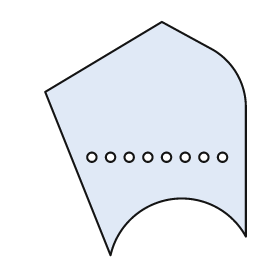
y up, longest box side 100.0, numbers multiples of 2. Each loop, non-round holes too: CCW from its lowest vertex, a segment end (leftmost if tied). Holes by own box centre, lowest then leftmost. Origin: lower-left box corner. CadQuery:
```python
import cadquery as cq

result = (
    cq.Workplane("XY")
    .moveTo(28.0, 0.0)
    .threePointArc((54.0, 24.0), (86.0, 8.0))
    .lineTo(86.0, 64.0)
    .threePointArc((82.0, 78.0), (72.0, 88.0))
    .lineTo(50.0, 100.0)
    .lineTo(0.0, 70.0)
    .close()
    .moveTo(20.0, 42.0)
    .circle(2.0)
    .moveTo(28.0, 42.0)
    .circle(2.0)
    .moveTo(36.0, 42.0)
    .circle(2.0)
    .moveTo(44.0, 42.0)
    .circle(2.0)
    .moveTo(52.0, 42.0)
    .circle(2.0)
    .moveTo(60.0, 42.0)
    .circle(2.0)
    .moveTo(68.0, 42.0)
    .circle(2.0)
    .moveTo(76.0, 42.0)
    .circle(2.0)
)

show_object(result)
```